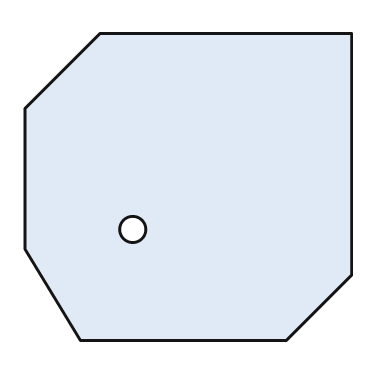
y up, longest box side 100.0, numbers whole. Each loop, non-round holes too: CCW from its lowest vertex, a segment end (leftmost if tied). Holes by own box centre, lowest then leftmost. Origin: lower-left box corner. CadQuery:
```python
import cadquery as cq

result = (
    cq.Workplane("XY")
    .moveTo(17.0, 0.0)
    .lineTo(80.0, 0.0)
    .lineTo(100.0, 20.0)
    .lineTo(100.0, 94.0)
    .lineTo(23.0, 94.0)
    .lineTo(0.0, 71.0)
    .lineTo(0.0, 28.0)
    .close()
    .moveTo(33.0, 34.0)
    .circle(4.0)
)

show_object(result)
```